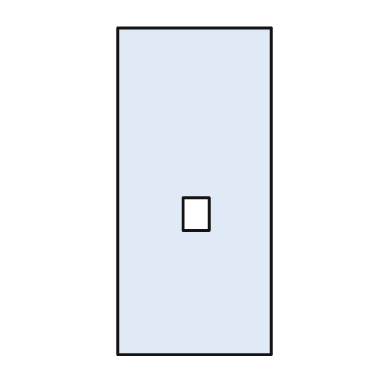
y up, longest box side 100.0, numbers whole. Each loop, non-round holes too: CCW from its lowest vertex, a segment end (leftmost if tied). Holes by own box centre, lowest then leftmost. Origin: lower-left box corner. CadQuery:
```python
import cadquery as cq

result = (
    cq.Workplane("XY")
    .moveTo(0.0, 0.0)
    .lineTo(47.0, 0.0)
    .lineTo(47.0, 100.0)
    .lineTo(0.0, 100.0)
    .close()
    .moveTo(20.0, 38.0)
    .lineTo(28.0, 38.0)
    .lineTo(28.0, 48.0)
    .lineTo(20.0, 48.0)
    .close()
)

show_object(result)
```